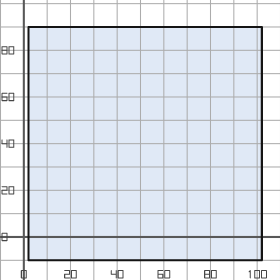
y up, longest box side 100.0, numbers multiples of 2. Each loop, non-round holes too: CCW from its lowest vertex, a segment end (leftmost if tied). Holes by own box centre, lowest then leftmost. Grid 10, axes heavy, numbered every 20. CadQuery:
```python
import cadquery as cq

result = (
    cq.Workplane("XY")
    .moveTo(2.0, -10.0)
    .lineTo(102.0, -10.0)
    .lineTo(102.0, 90.0)
    .lineTo(2.0, 90.0)
    .close()
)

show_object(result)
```